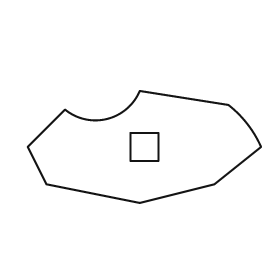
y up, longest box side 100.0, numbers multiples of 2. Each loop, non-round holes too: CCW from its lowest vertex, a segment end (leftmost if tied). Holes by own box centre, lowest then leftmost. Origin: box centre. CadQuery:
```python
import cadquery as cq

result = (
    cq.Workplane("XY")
    .moveTo(-2.0, -24.0)
    .lineTo(30.0, -16.0)
    .lineTo(50.0, 0.0)
    .threePointArc((44.0, 10.0), (36.0, 18.0))
    .lineTo(-2.0, 24.0)
    .threePointArc((-16.0, 12.0), (-34.0, 16.0))
    .lineTo(-50.0, 0.0)
    .lineTo(-42.0, -16.0)
    .close()
    .moveTo(-6.0, -6.0)
    .lineTo(6.0, -6.0)
    .lineTo(6.0, 6.0)
    .lineTo(-6.0, 6.0)
    .close()
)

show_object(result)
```